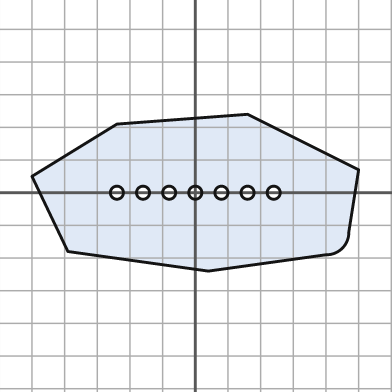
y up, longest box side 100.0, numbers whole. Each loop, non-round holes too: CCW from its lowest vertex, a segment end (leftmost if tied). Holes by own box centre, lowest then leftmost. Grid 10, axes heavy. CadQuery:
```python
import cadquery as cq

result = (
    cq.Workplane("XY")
    .moveTo(4.0, -24.0)
    .lineTo(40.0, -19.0)
    .threePointArc((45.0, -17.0), (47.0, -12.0))
    .lineTo(50.0, 7.0)
    .lineTo(16.0, 24.0)
    .lineTo(-24.0, 21.0)
    .lineTo(-50.0, 5.0)
    .lineTo(-39.0, -18.0)
    .close()
    .moveTo(-24.0, 0.0)
    .circle(2.0)
    .moveTo(-16.0, 0.0)
    .circle(2.0)
    .moveTo(-8.0, 0.0)
    .circle(2.0)
    .moveTo(0.0, 0.0)
    .circle(2.0)
    .moveTo(8.0, 0.0)
    .circle(2.0)
    .moveTo(16.0, 0.0)
    .circle(2.0)
    .moveTo(24.0, 0.0)
    .circle(2.0)
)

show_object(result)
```